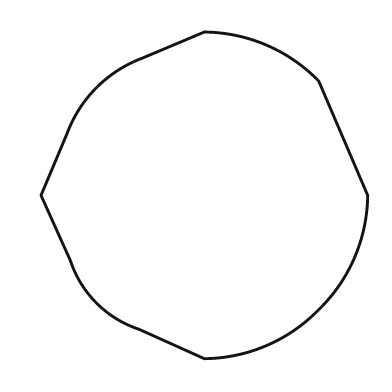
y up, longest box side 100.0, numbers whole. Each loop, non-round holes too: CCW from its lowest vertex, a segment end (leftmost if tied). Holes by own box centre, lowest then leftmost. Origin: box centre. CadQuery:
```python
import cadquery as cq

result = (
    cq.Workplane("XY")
    .moveTo(0.0, -50.0)
    .threePointArc((19.0, -46.0), (35.0, -35.0))
    .threePointArc((46.0, -19.0), (50.0, 0.0))
    .lineTo(35.0, 35.0)
    .threePointArc((19.0, 46.0), (0.0, 50.0))
    .lineTo(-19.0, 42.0)
    .threePointArc((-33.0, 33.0), (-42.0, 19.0))
    .lineTo(-50.0, 0.0)
    .lineTo(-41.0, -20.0)
    .threePointArc((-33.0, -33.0), (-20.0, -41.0))
    .close()
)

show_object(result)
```